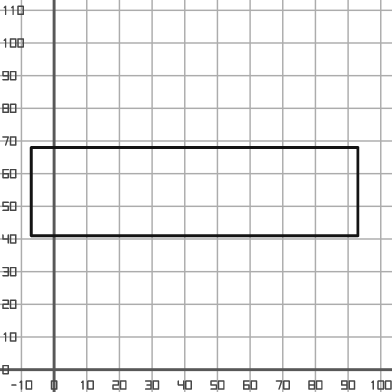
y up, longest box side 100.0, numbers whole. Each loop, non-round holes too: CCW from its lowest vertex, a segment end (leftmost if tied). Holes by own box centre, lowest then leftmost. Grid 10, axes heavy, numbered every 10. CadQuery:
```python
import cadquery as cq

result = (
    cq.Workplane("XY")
    .moveTo(-7.0, 41.0)
    .lineTo(93.0, 41.0)
    .lineTo(93.0, 68.0)
    .lineTo(-7.0, 68.0)
    .close()
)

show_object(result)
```